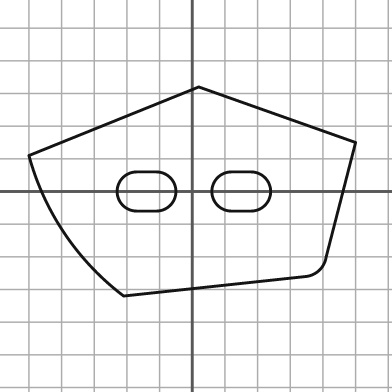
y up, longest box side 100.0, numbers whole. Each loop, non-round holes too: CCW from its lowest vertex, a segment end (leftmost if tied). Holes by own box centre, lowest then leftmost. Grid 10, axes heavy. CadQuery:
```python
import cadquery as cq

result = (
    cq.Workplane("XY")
    .moveTo(-21.0, -32.0)
    .lineTo(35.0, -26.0)
    .threePointArc((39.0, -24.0), (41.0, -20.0))
    .lineTo(50.0, 15.0)
    .lineTo(2.0, 32.0)
    .lineTo(-50.0, 11.0)
    .threePointArc((-39.0, -13.0), (-21.0, -32.0))
    .close()
    .moveTo(-17.0, -6.0)
    .lineTo(-11.0, -6.0)
    .threePointArc((-5.0, 0.0), (-11.0, 6.0))
    .lineTo(-17.0, 6.0)
    .threePointArc((-23.0, 0.0), (-17.0, -6.0))
    .close()
    .moveTo(12.0, -6.0)
    .lineTo(18.0, -6.0)
    .threePointArc((24.0, 0.0), (18.0, 6.0))
    .lineTo(12.0, 6.0)
    .threePointArc((6.0, 0.0), (12.0, -6.0))
    .close()
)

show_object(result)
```